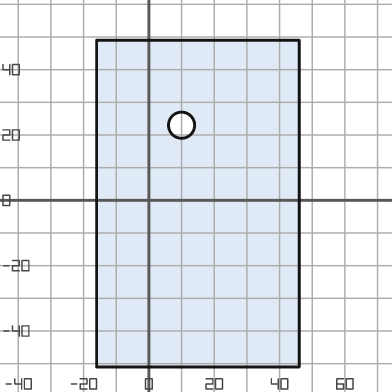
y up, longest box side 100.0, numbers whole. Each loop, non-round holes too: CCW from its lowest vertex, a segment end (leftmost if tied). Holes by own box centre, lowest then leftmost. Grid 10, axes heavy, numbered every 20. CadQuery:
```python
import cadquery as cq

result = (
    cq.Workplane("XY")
    .moveTo(-16.0, -51.0)
    .lineTo(46.0, -51.0)
    .lineTo(46.0, 49.0)
    .lineTo(-16.0, 49.0)
    .close()
    .moveTo(10.0, 23.0)
    .circle(4.0)
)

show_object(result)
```